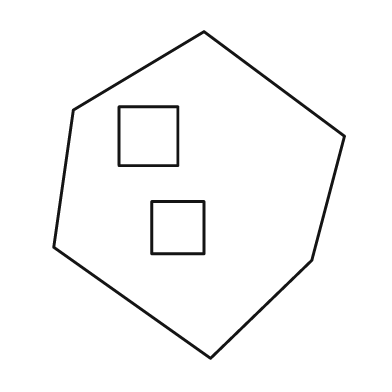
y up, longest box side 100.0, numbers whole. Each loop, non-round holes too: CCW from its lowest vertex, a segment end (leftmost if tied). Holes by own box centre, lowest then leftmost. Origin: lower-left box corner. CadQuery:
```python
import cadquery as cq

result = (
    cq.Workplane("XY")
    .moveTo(48.0, 0.0)
    .lineTo(79.0, 30.0)
    .lineTo(89.0, 68.0)
    .lineTo(46.0, 100.0)
    .lineTo(6.0, 76.0)
    .lineTo(0.0, 34.0)
    .close()
    .moveTo(30.0, 32.0)
    .lineTo(46.0, 32.0)
    .lineTo(46.0, 48.0)
    .lineTo(30.0, 48.0)
    .close()
    .moveTo(20.0, 59.0)
    .lineTo(38.0, 59.0)
    .lineTo(38.0, 77.0)
    .lineTo(20.0, 77.0)
    .close()
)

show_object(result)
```